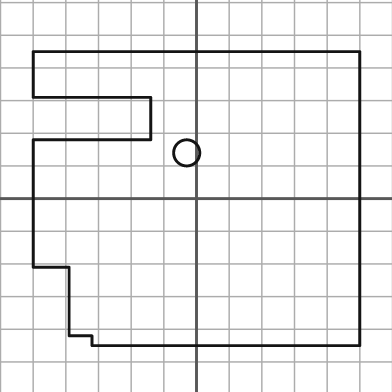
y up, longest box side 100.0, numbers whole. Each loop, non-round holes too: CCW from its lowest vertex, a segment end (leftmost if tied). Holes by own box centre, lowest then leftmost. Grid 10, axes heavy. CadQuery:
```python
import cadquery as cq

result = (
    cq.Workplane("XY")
    .moveTo(-32.0, -45.0)
    .lineTo(50.0, -45.0)
    .lineTo(50.0, 45.0)
    .lineTo(-50.0, 45.0)
    .lineTo(-50.0, 31.0)
    .lineTo(-14.0, 31.0)
    .lineTo(-14.0, 18.0)
    .lineTo(-50.0, 18.0)
    .lineTo(-50.0, -21.0)
    .lineTo(-39.0, -21.0)
    .lineTo(-39.0, -42.0)
    .lineTo(-32.0, -42.0)
    .close()
    .moveTo(-3.0, 14.0)
    .circle(4.0)
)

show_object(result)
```